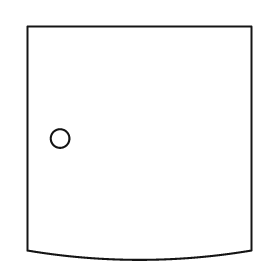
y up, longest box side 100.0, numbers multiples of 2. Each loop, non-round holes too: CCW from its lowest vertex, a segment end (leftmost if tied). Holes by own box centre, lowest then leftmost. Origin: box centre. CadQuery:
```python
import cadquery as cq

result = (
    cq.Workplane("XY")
    .moveTo(-48.0, -46.0)
    .threePointArc((0.0, -50.0), (48.0, -46.0))
    .lineTo(48.0, 50.0)
    .lineTo(-48.0, 50.0)
    .close()
    .moveTo(-34.0, 2.0)
    .circle(4.0)
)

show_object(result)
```